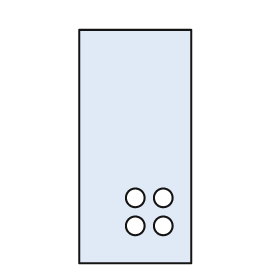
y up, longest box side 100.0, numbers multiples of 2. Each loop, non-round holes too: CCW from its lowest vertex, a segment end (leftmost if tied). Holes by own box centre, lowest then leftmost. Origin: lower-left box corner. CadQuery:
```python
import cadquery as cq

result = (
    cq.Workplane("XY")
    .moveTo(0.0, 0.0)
    .lineTo(48.0, 0.0)
    .lineTo(48.0, 100.0)
    .lineTo(0.0, 100.0)
    .close()
    .moveTo(24.0, 16.0)
    .circle(4.0)
    .moveTo(36.0, 16.0)
    .circle(4.0)
    .moveTo(24.0, 28.0)
    .circle(4.0)
    .moveTo(36.0, 28.0)
    .circle(4.0)
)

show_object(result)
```